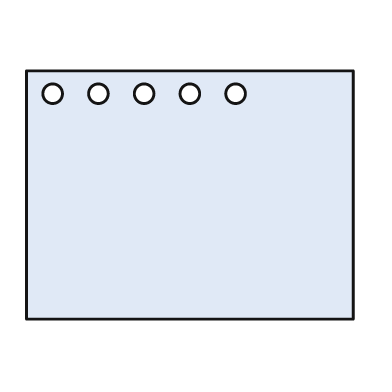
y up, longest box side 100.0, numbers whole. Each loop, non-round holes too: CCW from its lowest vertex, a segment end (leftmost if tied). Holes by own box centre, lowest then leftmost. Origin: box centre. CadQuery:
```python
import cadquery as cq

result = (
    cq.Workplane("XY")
    .moveTo(-50.0, -38.0)
    .lineTo(50.0, -38.0)
    .lineTo(50.0, 38.0)
    .lineTo(-50.0, 38.0)
    .close()
    .moveTo(-42.0, 31.0)
    .circle(3.0)
    .moveTo(-28.0, 31.0)
    .circle(3.0)
    .moveTo(-14.0, 31.0)
    .circle(3.0)
    .moveTo(0.0, 31.0)
    .circle(3.0)
    .moveTo(14.0, 31.0)
    .circle(3.0)
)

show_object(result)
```